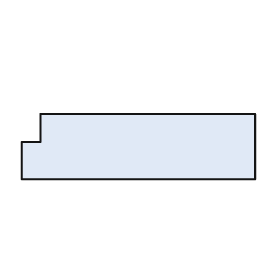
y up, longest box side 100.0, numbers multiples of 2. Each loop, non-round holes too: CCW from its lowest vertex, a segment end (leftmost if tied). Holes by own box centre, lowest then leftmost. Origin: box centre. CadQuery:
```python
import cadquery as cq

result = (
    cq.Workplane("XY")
    .moveTo(-50.0, -14.0)
    .lineTo(50.0, -14.0)
    .lineTo(50.0, 14.0)
    .lineTo(-42.0, 14.0)
    .lineTo(-42.0, 2.0)
    .lineTo(-50.0, 2.0)
    .close()
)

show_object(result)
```